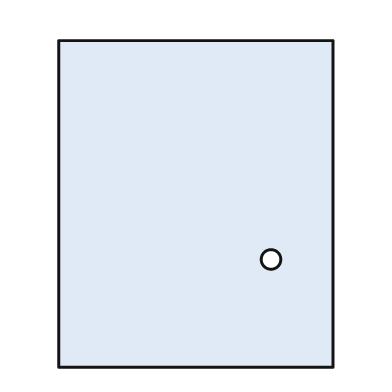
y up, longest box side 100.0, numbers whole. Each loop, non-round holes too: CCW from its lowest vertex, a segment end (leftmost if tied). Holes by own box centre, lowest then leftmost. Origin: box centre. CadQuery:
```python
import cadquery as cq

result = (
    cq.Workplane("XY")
    .moveTo(-42.0, -50.0)
    .lineTo(42.0, -50.0)
    .lineTo(42.0, 50.0)
    .lineTo(-42.0, 50.0)
    .close()
    .moveTo(23.0, -17.0)
    .circle(3.0)
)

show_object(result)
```